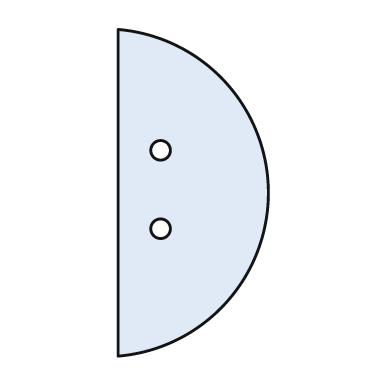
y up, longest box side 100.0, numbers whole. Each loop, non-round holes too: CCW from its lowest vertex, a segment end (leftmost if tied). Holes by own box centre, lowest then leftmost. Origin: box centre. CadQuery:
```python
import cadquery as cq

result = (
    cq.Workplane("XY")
    .moveTo(-23.0, -50.0)
    .threePointArc((23.0, 0.0), (-23.0, 50.0))
    .close()
    .moveTo(-10.0, -11.0)
    .circle(3.0)
    .moveTo(-10.0, 13.0)
    .circle(3.0)
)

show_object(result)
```